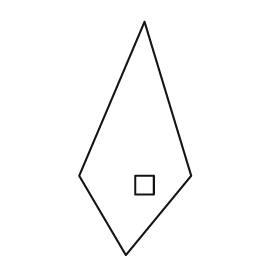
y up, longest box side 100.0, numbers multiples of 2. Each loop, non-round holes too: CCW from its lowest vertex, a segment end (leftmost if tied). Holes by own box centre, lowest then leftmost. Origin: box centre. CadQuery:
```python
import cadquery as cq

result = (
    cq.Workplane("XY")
    .moveTo(-4.0, -50.0)
    .lineTo(24.0, -16.0)
    .lineTo(4.0, 50.0)
    .lineTo(-24.0, -16.0)
    .close()
    .moveTo(0.0, -24.0)
    .lineTo(8.0, -24.0)
    .lineTo(8.0, -16.0)
    .lineTo(0.0, -16.0)
    .close()
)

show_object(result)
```